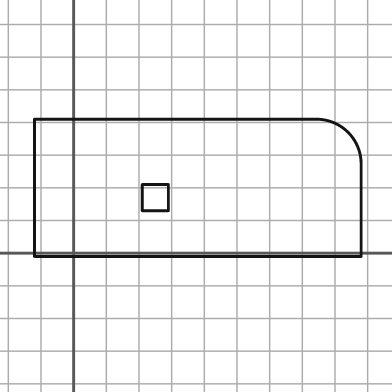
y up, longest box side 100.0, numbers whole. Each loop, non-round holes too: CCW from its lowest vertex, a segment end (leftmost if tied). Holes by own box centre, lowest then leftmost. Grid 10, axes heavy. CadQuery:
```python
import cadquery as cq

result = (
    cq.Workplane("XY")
    .moveTo(-12.0, -1.0)
    .lineTo(88.0, -1.0)
    .lineTo(88.0, 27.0)
    .threePointArc((84.0, 37.0), (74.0, 41.0))
    .lineTo(-12.0, 41.0)
    .close()
    .moveTo(21.0, 13.0)
    .lineTo(29.0, 13.0)
    .lineTo(29.0, 21.0)
    .lineTo(21.0, 21.0)
    .close()
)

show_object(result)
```